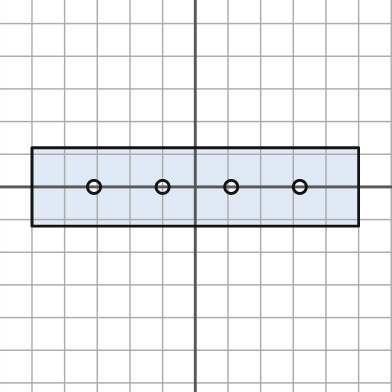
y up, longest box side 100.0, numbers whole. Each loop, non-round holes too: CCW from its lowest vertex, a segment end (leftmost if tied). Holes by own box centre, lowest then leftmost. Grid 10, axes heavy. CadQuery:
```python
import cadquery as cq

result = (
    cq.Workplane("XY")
    .moveTo(-50.0, -12.0)
    .lineTo(50.0, -12.0)
    .lineTo(50.0, 12.0)
    .lineTo(-50.0, 12.0)
    .close()
    .moveTo(-31.0, 0.0)
    .circle(2.0)
    .moveTo(-10.0, 0.0)
    .circle(2.0)
    .moveTo(11.0, 0.0)
    .circle(2.0)
    .moveTo(32.0, 0.0)
    .circle(2.0)
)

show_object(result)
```